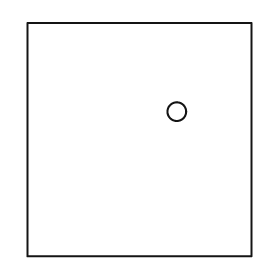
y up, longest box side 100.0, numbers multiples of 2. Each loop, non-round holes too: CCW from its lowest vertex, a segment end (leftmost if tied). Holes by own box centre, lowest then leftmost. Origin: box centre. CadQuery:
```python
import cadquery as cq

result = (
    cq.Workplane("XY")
    .moveTo(-48.0, -50.0)
    .lineTo(48.0, -50.0)
    .lineTo(48.0, 50.0)
    .lineTo(-48.0, 50.0)
    .close()
    .moveTo(16.0, 12.0)
    .circle(4.0)
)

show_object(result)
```